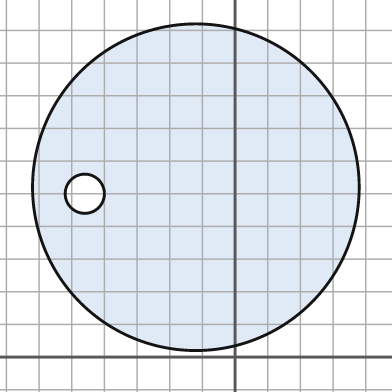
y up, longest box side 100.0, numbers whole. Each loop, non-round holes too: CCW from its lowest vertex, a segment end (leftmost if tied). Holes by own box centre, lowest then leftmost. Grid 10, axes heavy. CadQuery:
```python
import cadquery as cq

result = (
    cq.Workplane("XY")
    .moveTo(-12.0, 52.0)
    .circle(50.0)
    .moveTo(-46.0, 50.0)
    .circle(6.0)
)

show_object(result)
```